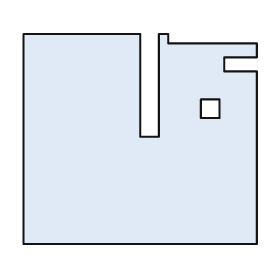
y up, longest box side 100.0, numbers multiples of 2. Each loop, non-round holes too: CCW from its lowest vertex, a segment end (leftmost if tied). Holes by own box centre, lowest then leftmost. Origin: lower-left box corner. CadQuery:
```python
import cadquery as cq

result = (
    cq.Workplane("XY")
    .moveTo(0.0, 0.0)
    .lineTo(100.0, 0.0)
    .lineTo(100.0, 74.0)
    .lineTo(86.0, 74.0)
    .lineTo(86.0, 80.0)
    .lineTo(100.0, 80.0)
    .lineTo(100.0, 86.0)
    .lineTo(62.0, 86.0)
    .lineTo(62.0, 90.0)
    .lineTo(58.0, 90.0)
    .lineTo(58.0, 46.0)
    .lineTo(50.0, 46.0)
    .lineTo(50.0, 90.0)
    .lineTo(0.0, 90.0)
    .close()
    .moveTo(76.0, 54.0)
    .lineTo(84.0, 54.0)
    .lineTo(84.0, 62.0)
    .lineTo(76.0, 62.0)
    .close()
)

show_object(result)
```